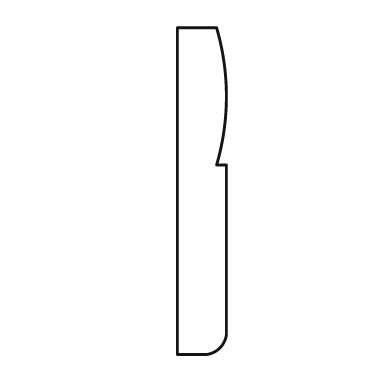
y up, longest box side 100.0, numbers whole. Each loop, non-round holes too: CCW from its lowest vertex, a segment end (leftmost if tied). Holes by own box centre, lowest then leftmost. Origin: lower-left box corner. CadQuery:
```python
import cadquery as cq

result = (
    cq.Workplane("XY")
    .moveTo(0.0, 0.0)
    .lineTo(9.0, 0.0)
    .threePointArc((13.0, 2.0), (15.0, 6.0))
    .lineTo(15.0, 58.0)
    .lineTo(12.0, 58.0)
    .threePointArc((15.0, 79.0), (12.0, 100.0))
    .lineTo(0.0, 100.0)
    .close()
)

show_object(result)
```